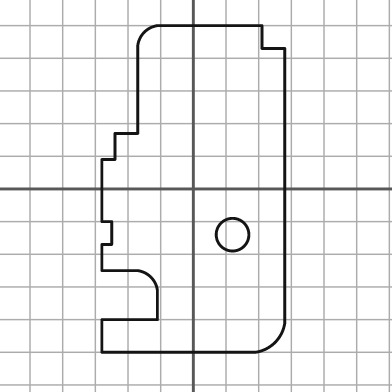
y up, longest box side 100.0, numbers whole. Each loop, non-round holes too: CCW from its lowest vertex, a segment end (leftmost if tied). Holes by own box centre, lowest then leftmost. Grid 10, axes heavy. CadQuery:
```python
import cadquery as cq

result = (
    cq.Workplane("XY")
    .moveTo(-28.0, -50.0)
    .lineTo(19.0, -50.0)
    .threePointArc((25.0, -47.0), (28.0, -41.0))
    .lineTo(28.0, 43.0)
    .lineTo(21.0, 43.0)
    .lineTo(21.0, 50.0)
    .lineTo(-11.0, 50.0)
    .threePointArc((-15.0, 48.0), (-17.0, 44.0))
    .lineTo(-17.0, 17.0)
    .lineTo(-24.0, 17.0)
    .lineTo(-24.0, 9.0)
    .lineTo(-28.0, 9.0)
    .lineTo(-28.0, -10.0)
    .lineTo(-25.0, -10.0)
    .lineTo(-25.0, -17.0)
    .lineTo(-28.0, -17.0)
    .lineTo(-28.0, -25.0)
    .lineTo(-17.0, -25.0)
    .threePointArc((-13.0, -27.0), (-11.0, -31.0))
    .lineTo(-11.0, -40.0)
    .lineTo(-28.0, -40.0)
    .close()
    .moveTo(12.0, -14.0)
    .circle(5.0)
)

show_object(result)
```